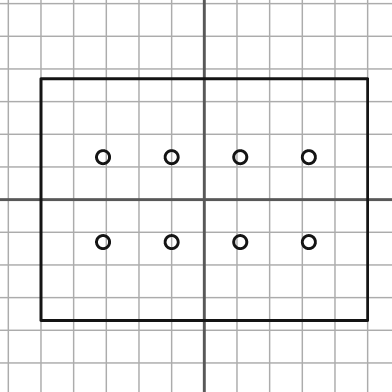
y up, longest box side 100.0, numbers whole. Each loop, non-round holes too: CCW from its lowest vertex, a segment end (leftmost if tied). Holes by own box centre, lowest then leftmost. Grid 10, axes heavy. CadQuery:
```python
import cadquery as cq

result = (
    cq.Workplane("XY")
    .moveTo(-50.0, -37.0)
    .lineTo(50.0, -37.0)
    .lineTo(50.0, 37.0)
    .lineTo(-50.0, 37.0)
    .close()
    .moveTo(-31.0, -13.0)
    .circle(2.0)
    .moveTo(-10.0, -13.0)
    .circle(2.0)
    .moveTo(11.0, -13.0)
    .circle(2.0)
    .moveTo(32.0, -13.0)
    .circle(2.0)
    .moveTo(-31.0, 13.0)
    .circle(2.0)
    .moveTo(-10.0, 13.0)
    .circle(2.0)
    .moveTo(11.0, 13.0)
    .circle(2.0)
    .moveTo(32.0, 13.0)
    .circle(2.0)
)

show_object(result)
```